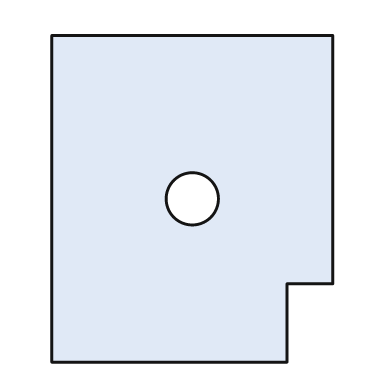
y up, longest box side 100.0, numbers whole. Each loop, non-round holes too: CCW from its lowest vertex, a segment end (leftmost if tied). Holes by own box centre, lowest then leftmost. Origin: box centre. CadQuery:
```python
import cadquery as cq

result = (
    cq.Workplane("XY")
    .moveTo(-43.0, -50.0)
    .lineTo(29.0, -50.0)
    .lineTo(29.0, -26.0)
    .lineTo(43.0, -26.0)
    .lineTo(43.0, 50.0)
    .lineTo(-43.0, 50.0)
    .close()
    .moveTo(0.0, 0.0)
    .circle(8.0)
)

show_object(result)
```